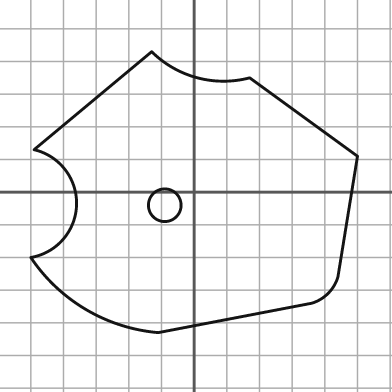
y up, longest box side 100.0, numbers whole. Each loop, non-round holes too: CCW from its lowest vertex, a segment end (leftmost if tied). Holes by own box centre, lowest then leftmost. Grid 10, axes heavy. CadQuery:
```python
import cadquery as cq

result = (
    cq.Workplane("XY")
    .moveTo(-11.0, -43.0)
    .lineTo(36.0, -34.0)
    .threePointArc((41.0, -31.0), (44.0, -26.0))
    .lineTo(50.0, 11.0)
    .lineTo(17.0, 35.0)
    .threePointArc((1.0, 35.0), (-13.0, 43.0))
    .lineTo(-49.0, 13.0)
    .threePointArc((-36.0, -4.0), (-50.0, -20.0))
    .threePointArc((-33.0, -36.0), (-11.0, -43.0))
    .close()
    .moveTo(-9.0, -4.0)
    .circle(5.0)
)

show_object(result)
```